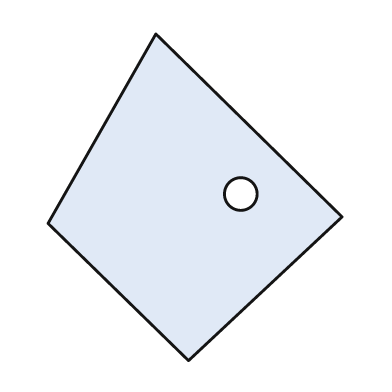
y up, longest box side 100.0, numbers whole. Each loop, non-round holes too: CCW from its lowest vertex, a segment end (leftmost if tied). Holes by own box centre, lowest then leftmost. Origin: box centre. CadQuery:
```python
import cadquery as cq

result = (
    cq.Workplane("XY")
    .moveTo(-2.0, -50.0)
    .lineTo(45.0, -6.0)
    .lineTo(-12.0, 50.0)
    .lineTo(-45.0, -8.0)
    .close()
    .moveTo(14.0, 1.0)
    .circle(5.0)
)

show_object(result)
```